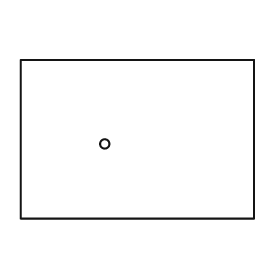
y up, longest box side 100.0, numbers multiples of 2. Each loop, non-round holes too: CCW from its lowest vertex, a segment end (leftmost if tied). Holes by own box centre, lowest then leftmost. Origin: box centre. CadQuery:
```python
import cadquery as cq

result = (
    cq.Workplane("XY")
    .moveTo(-50.0, -34.0)
    .lineTo(50.0, -34.0)
    .lineTo(50.0, 34.0)
    .lineTo(-50.0, 34.0)
    .close()
    .moveTo(-14.0, -2.0)
    .circle(2.0)
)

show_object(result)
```